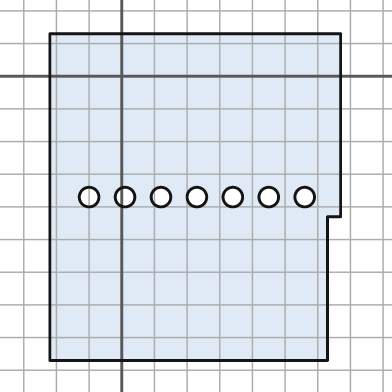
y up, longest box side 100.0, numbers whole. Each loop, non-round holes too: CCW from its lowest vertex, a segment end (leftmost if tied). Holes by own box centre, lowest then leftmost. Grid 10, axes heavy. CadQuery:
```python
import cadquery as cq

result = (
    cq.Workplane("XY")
    .moveTo(-22.0, -87.0)
    .lineTo(63.0, -87.0)
    .lineTo(63.0, -43.0)
    .lineTo(67.0, -43.0)
    .lineTo(67.0, 13.0)
    .lineTo(-22.0, 13.0)
    .close()
    .moveTo(-10.0, -37.0)
    .circle(3.0)
    .moveTo(1.0, -37.0)
    .circle(3.0)
    .moveTo(12.0, -37.0)
    .circle(3.0)
    .moveTo(23.0, -37.0)
    .circle(3.0)
    .moveTo(34.0, -37.0)
    .circle(3.0)
    .moveTo(45.0, -37.0)
    .circle(3.0)
    .moveTo(56.0, -37.0)
    .circle(3.0)
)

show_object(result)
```